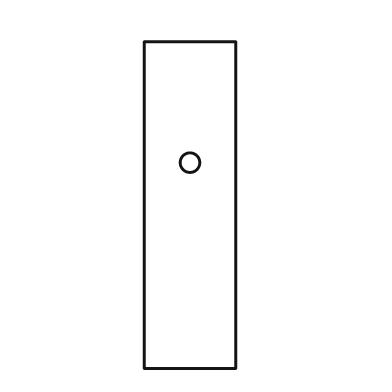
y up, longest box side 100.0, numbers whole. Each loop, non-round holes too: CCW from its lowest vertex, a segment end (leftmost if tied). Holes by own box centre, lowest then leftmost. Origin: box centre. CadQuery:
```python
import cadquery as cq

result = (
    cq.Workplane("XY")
    .moveTo(-14.0, -50.0)
    .lineTo(14.0, -50.0)
    .lineTo(14.0, 50.0)
    .lineTo(-14.0, 50.0)
    .close()
    .moveTo(0.0, 13.0)
    .circle(3.0)
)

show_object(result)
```